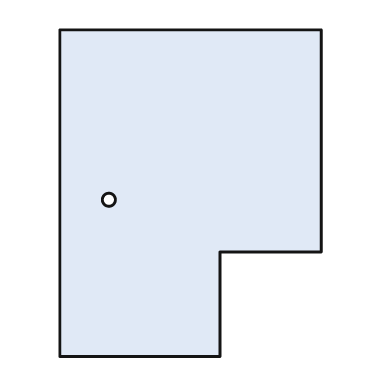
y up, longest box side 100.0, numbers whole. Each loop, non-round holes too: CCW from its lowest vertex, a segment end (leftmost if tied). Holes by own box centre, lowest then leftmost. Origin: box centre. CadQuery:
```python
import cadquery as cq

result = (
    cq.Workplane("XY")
    .moveTo(-40.0, -50.0)
    .lineTo(9.0, -50.0)
    .lineTo(9.0, -18.0)
    .lineTo(40.0, -18.0)
    .lineTo(40.0, 50.0)
    .lineTo(-40.0, 50.0)
    .close()
    .moveTo(-25.0, -2.0)
    .circle(2.0)
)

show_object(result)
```